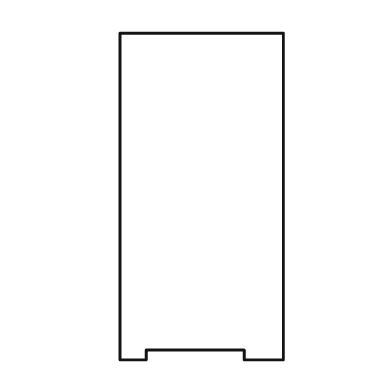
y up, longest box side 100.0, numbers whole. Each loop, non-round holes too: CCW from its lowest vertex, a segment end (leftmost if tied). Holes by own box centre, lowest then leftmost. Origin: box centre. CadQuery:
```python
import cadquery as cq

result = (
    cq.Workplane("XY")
    .moveTo(-25.0, -50.0)
    .lineTo(-17.0, -50.0)
    .lineTo(-17.0, -47.0)
    .lineTo(13.0, -47.0)
    .lineTo(13.0, -50.0)
    .lineTo(25.0, -50.0)
    .lineTo(25.0, 50.0)
    .lineTo(-25.0, 50.0)
    .close()
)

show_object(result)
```